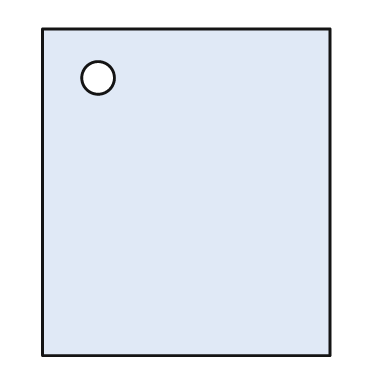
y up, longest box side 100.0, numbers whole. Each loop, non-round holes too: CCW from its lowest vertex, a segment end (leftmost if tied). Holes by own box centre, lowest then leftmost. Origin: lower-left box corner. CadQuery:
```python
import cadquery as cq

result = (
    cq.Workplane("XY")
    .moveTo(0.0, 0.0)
    .lineTo(88.0, 0.0)
    .lineTo(88.0, 100.0)
    .lineTo(0.0, 100.0)
    .close()
    .moveTo(17.0, 85.0)
    .circle(5.0)
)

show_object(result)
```